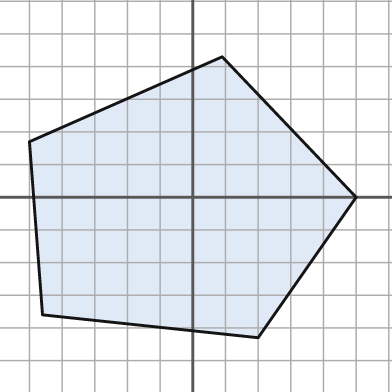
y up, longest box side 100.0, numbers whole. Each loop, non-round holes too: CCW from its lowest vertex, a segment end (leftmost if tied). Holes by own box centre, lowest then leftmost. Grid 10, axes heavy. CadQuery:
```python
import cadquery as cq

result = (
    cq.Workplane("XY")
    .moveTo(20.0, -43.0)
    .lineTo(50.0, 0.0)
    .lineTo(9.0, 43.0)
    .lineTo(-50.0, 17.0)
    .lineTo(-46.0, -36.0)
    .close()
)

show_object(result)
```